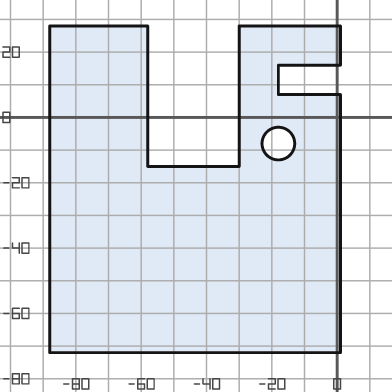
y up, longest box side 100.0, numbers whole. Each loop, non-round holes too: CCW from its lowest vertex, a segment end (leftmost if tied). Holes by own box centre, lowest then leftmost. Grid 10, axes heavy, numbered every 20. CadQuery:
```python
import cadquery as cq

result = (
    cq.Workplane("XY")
    .moveTo(-88.0, -72.0)
    .lineTo(1.0, -72.0)
    .lineTo(1.0, 7.0)
    .lineTo(-18.0, 7.0)
    .lineTo(-18.0, 16.0)
    .lineTo(1.0, 16.0)
    .lineTo(1.0, 28.0)
    .lineTo(-30.0, 28.0)
    .lineTo(-30.0, -15.0)
    .lineTo(-58.0, -15.0)
    .lineTo(-58.0, 28.0)
    .lineTo(-88.0, 28.0)
    .close()
    .moveTo(-18.0, -8.0)
    .circle(5.0)
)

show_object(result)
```